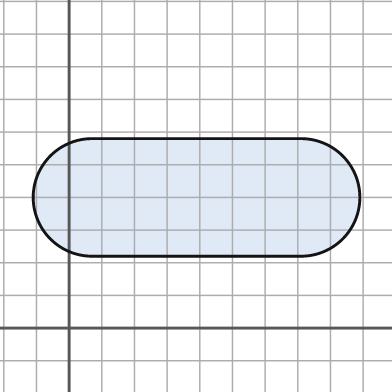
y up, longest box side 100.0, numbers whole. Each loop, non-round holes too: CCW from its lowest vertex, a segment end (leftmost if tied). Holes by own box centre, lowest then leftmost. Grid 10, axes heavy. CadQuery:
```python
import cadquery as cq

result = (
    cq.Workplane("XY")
    .moveTo(7.0, 22.0)
    .lineTo(71.0, 22.0)
    .threePointArc((89.0, 40.0), (71.0, 58.0))
    .lineTo(7.0, 58.0)
    .threePointArc((-11.0, 40.0), (7.0, 22.0))
    .close()
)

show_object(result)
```